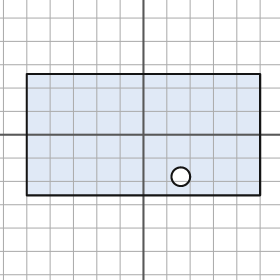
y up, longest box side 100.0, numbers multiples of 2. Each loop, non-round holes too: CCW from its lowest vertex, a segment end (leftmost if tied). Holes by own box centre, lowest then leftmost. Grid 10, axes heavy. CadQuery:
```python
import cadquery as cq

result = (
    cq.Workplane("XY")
    .moveTo(-50.0, -26.0)
    .lineTo(50.0, -26.0)
    .lineTo(50.0, 26.0)
    .lineTo(-50.0, 26.0)
    .close()
    .moveTo(16.0, -18.0)
    .circle(4.0)
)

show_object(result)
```